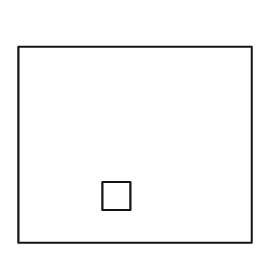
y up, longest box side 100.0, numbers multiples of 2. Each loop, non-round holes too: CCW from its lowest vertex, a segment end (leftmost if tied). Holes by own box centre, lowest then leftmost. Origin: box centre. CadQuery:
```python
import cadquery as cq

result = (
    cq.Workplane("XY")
    .moveTo(-50.0, -42.0)
    .lineTo(50.0, -42.0)
    .lineTo(50.0, 42.0)
    .lineTo(-50.0, 42.0)
    .close()
    .moveTo(-14.0, -28.0)
    .lineTo(-2.0, -28.0)
    .lineTo(-2.0, -16.0)
    .lineTo(-14.0, -16.0)
    .close()
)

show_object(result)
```